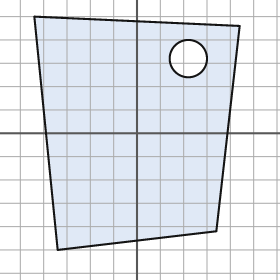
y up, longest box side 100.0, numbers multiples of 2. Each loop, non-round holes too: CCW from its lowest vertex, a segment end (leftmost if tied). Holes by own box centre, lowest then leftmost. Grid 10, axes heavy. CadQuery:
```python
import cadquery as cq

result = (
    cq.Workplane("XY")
    .moveTo(-34.0, -50.0)
    .lineTo(34.0, -42.0)
    .lineTo(44.0, 46.0)
    .lineTo(-44.0, 50.0)
    .close()
    .moveTo(22.0, 32.0)
    .circle(8.0)
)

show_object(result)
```